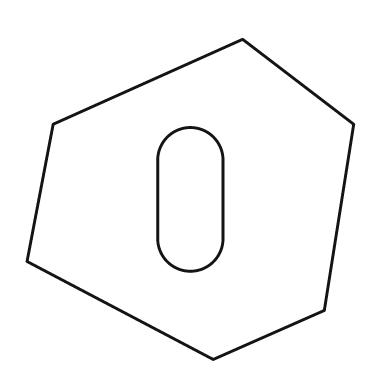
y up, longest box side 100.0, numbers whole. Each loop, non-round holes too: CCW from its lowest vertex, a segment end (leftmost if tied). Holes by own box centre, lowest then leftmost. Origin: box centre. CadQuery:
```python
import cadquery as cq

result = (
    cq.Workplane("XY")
    .moveTo(7.0, -49.0)
    .lineTo(41.0, -34.0)
    .lineTo(50.0, 23.0)
    .lineTo(16.0, 49.0)
    .lineTo(-42.0, 23.0)
    .lineTo(-50.0, -19.0)
    .close()
    .moveTo(-10.0, -12.0)
    .threePointArc((0.0, -22.0), (10.0, -12.0))
    .lineTo(10.0, 12.0)
    .threePointArc((0.0, 22.0), (-10.0, 12.0))
    .close()
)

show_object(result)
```